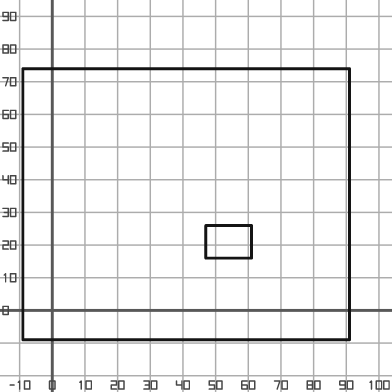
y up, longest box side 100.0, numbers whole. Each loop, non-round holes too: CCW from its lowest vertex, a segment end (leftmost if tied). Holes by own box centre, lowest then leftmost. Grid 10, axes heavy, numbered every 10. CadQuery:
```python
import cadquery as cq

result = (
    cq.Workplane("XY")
    .moveTo(-9.0, -9.0)
    .lineTo(91.0, -9.0)
    .lineTo(91.0, 74.0)
    .lineTo(-9.0, 74.0)
    .close()
    .moveTo(47.0, 16.0)
    .lineTo(61.0, 16.0)
    .lineTo(61.0, 26.0)
    .lineTo(47.0, 26.0)
    .close()
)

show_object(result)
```